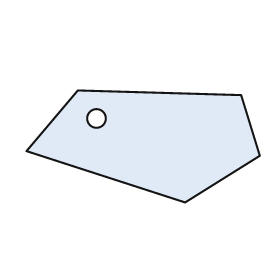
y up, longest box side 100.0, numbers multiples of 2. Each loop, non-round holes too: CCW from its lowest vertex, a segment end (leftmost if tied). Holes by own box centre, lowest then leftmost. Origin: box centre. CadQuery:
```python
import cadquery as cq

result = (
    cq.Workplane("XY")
    .moveTo(18.0, -24.0)
    .lineTo(50.0, -4.0)
    .lineTo(42.0, 22.0)
    .lineTo(-28.0, 24.0)
    .lineTo(-50.0, -2.0)
    .close()
    .moveTo(-20.0, 12.0)
    .circle(4.0)
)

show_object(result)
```